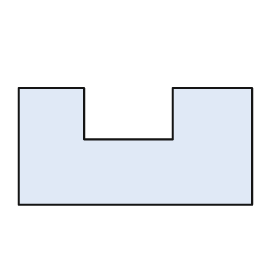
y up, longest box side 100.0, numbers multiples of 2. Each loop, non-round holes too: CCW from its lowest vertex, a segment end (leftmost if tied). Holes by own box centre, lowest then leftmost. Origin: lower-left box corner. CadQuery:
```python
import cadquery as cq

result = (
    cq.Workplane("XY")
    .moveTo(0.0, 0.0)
    .lineTo(100.0, 0.0)
    .lineTo(100.0, 50.0)
    .lineTo(66.0, 50.0)
    .lineTo(66.0, 28.0)
    .lineTo(28.0, 28.0)
    .lineTo(28.0, 50.0)
    .lineTo(0.0, 50.0)
    .close()
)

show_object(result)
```